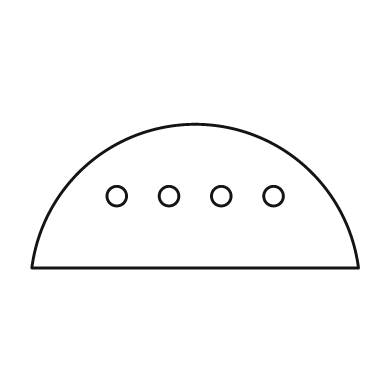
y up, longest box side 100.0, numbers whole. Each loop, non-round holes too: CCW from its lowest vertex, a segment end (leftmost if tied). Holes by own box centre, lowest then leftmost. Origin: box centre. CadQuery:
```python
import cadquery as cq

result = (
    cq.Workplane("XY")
    .moveTo(-50.0, -22.0)
    .lineTo(50.0, -22.0)
    .threePointArc((0.0, 22.0), (-50.0, -22.0))
    .close()
    .moveTo(-24.0, 0.0)
    .circle(3.0)
    .moveTo(-8.0, 0.0)
    .circle(3.0)
    .moveTo(8.0, 0.0)
    .circle(3.0)
    .moveTo(24.0, 0.0)
    .circle(3.0)
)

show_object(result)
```